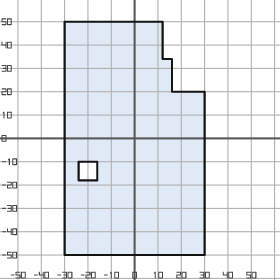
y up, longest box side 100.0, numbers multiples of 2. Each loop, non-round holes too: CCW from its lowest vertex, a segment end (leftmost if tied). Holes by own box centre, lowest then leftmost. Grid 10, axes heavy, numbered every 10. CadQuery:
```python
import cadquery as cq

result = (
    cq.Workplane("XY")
    .moveTo(-30.0, -50.0)
    .lineTo(30.0, -50.0)
    .lineTo(30.0, 20.0)
    .lineTo(16.0, 20.0)
    .lineTo(16.0, 34.0)
    .lineTo(12.0, 34.0)
    .lineTo(12.0, 50.0)
    .lineTo(-30.0, 50.0)
    .close()
    .moveTo(-24.0, -18.0)
    .lineTo(-16.0, -18.0)
    .lineTo(-16.0, -10.0)
    .lineTo(-24.0, -10.0)
    .close()
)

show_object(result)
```